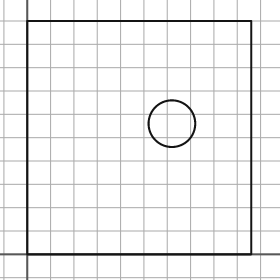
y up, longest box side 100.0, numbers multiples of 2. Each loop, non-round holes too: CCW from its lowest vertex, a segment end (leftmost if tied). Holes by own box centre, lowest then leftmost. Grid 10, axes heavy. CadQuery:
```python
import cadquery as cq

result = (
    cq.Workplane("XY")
    .moveTo(0.0, 0.0)
    .lineTo(96.0, 0.0)
    .lineTo(96.0, 100.0)
    .lineTo(0.0, 100.0)
    .close()
    .moveTo(62.0, 56.0)
    .circle(10.0)
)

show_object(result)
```